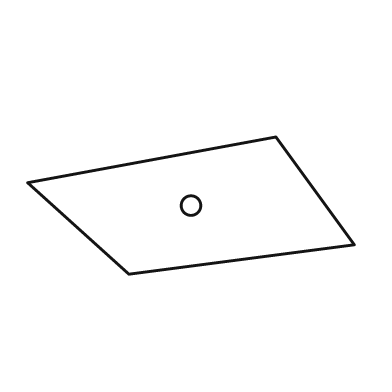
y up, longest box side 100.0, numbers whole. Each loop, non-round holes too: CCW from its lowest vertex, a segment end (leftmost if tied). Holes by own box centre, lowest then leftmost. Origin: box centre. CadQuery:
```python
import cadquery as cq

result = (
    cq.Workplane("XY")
    .moveTo(-19.0, -21.0)
    .lineTo(50.0, -12.0)
    .lineTo(26.0, 21.0)
    .lineTo(-50.0, 7.0)
    .close()
    .moveTo(0.0, 0.0)
    .circle(3.0)
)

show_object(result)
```